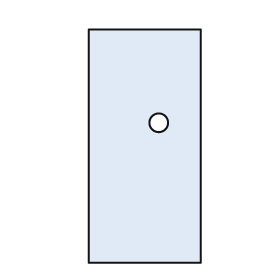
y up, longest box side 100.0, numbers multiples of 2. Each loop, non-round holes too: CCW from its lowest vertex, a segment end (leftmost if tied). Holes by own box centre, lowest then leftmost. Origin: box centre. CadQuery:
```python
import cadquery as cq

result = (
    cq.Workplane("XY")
    .moveTo(-24.0, -50.0)
    .lineTo(24.0, -50.0)
    .lineTo(24.0, 50.0)
    .lineTo(-24.0, 50.0)
    .close()
    .moveTo(6.0, 10.0)
    .circle(4.0)
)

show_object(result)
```